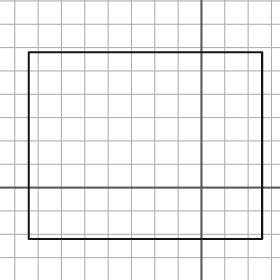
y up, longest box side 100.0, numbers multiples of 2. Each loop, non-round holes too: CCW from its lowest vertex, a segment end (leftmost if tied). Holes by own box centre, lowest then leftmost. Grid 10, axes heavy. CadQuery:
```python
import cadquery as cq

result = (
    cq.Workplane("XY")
    .moveTo(-74.0, -22.0)
    .lineTo(26.0, -22.0)
    .lineTo(26.0, 58.0)
    .lineTo(-74.0, 58.0)
    .close()
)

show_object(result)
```